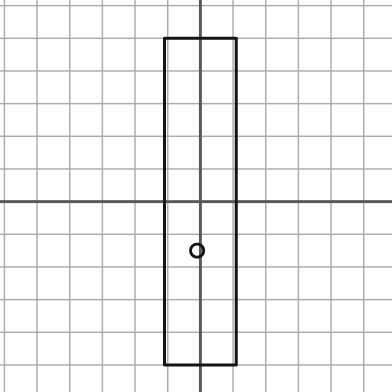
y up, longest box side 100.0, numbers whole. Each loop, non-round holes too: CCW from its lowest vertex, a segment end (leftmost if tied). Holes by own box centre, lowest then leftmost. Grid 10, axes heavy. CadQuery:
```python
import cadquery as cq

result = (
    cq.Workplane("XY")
    .moveTo(-11.0, -50.0)
    .lineTo(11.0, -50.0)
    .lineTo(11.0, 50.0)
    .lineTo(-11.0, 50.0)
    .close()
    .moveTo(-1.0, -15.0)
    .circle(2.0)
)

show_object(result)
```